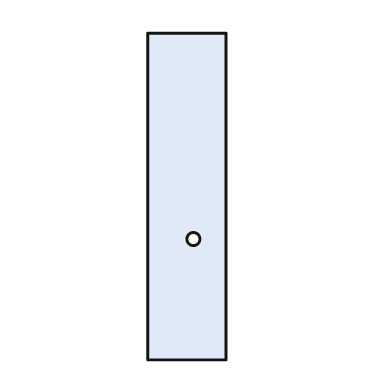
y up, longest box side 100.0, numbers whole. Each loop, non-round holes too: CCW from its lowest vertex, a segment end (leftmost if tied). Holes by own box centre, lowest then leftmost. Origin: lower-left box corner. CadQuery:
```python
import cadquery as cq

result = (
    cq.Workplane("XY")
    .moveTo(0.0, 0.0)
    .lineTo(24.0, 0.0)
    .lineTo(24.0, 100.0)
    .lineTo(0.0, 100.0)
    .close()
    .moveTo(14.0, 37.0)
    .circle(2.0)
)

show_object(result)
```